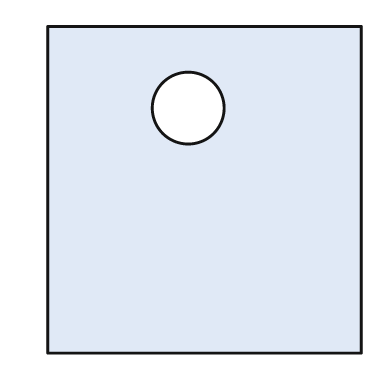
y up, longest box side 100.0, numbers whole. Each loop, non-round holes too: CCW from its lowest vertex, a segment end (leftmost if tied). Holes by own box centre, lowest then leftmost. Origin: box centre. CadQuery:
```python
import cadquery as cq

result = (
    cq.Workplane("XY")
    .moveTo(-48.0, -50.0)
    .lineTo(48.0, -50.0)
    .lineTo(48.0, 50.0)
    .lineTo(-48.0, 50.0)
    .close()
    .moveTo(-5.0, 25.0)
    .circle(11.0)
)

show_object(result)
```